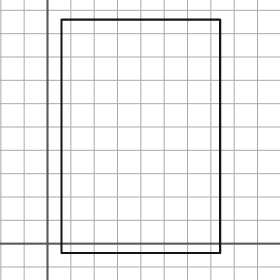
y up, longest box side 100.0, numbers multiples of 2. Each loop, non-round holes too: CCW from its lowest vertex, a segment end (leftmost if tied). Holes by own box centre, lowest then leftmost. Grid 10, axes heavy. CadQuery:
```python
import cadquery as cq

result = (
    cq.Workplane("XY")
    .moveTo(6.0, -4.0)
    .lineTo(74.0, -4.0)
    .lineTo(74.0, 96.0)
    .lineTo(6.0, 96.0)
    .close()
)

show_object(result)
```